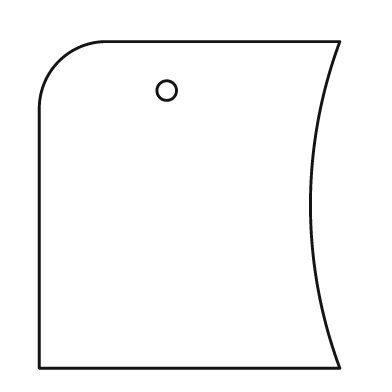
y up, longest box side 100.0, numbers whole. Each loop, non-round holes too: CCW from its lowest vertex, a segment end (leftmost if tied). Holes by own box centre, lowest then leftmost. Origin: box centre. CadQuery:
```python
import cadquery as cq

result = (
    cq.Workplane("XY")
    .moveTo(-46.0, -50.0)
    .lineTo(46.0, -50.0)
    .threePointArc((37.0, 0.0), (46.0, 50.0))
    .lineTo(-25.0, 50.0)
    .threePointArc((-40.0, 44.0), (-46.0, 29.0))
    .close()
    .moveTo(-7.0, 35.0)
    .circle(3.0)
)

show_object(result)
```